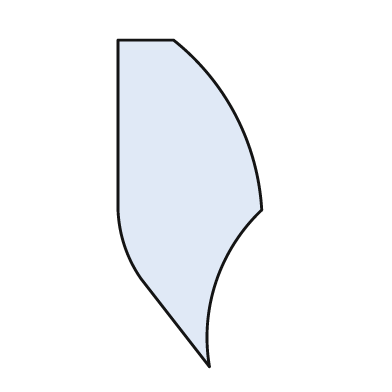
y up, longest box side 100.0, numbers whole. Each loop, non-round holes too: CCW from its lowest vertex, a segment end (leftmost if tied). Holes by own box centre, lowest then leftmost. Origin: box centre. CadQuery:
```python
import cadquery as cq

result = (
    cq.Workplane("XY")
    .moveTo(6.0, -50.0)
    .threePointArc((8.0, -24.0), (22.0, -2.0))
    .threePointArc((14.0, 27.0), (-5.0, 50.0))
    .lineTo(-22.0, 50.0)
    .lineTo(-22.0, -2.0)
    .threePointArc((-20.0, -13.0), (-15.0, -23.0))
    .close()
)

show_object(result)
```